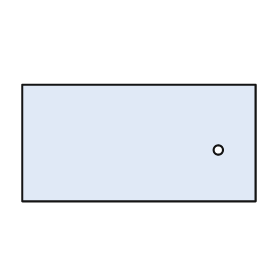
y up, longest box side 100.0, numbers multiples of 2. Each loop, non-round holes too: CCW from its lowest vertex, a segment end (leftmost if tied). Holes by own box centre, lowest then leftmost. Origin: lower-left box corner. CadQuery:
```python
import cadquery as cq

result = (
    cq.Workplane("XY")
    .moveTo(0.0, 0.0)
    .lineTo(100.0, 0.0)
    .lineTo(100.0, 50.0)
    .lineTo(0.0, 50.0)
    .close()
    .moveTo(84.0, 22.0)
    .circle(2.0)
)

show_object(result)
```